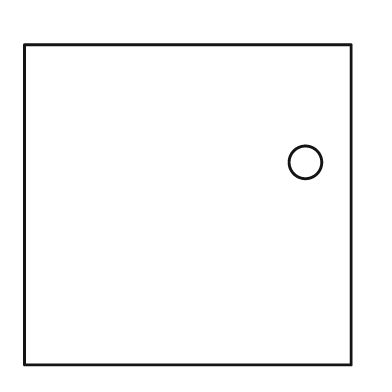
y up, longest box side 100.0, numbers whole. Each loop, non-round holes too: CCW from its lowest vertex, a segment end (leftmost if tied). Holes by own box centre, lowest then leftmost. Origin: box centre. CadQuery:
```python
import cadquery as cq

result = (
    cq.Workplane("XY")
    .moveTo(-50.0, -49.0)
    .lineTo(50.0, -49.0)
    .lineTo(50.0, 49.0)
    .lineTo(-50.0, 49.0)
    .close()
    .moveTo(36.0, 13.0)
    .circle(5.0)
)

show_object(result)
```